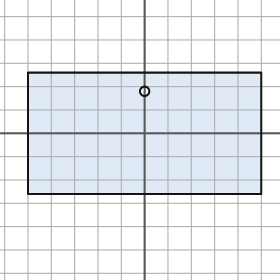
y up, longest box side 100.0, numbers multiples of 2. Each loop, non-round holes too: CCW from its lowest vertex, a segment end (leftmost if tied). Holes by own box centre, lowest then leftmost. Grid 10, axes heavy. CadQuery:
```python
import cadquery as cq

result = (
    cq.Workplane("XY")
    .moveTo(-50.0, -26.0)
    .lineTo(50.0, -26.0)
    .lineTo(50.0, 26.0)
    .lineTo(-50.0, 26.0)
    .close()
    .moveTo(0.0, 18.0)
    .circle(2.0)
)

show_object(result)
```